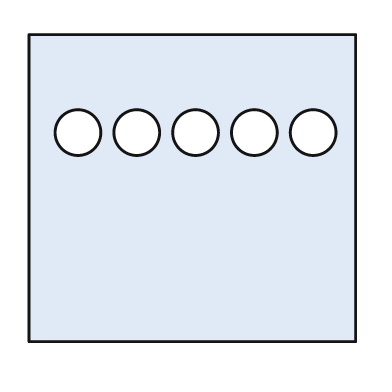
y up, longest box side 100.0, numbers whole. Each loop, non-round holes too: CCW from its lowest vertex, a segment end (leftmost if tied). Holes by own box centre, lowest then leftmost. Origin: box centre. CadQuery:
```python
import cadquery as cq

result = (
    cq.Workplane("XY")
    .moveTo(-50.0, -47.0)
    .lineTo(50.0, -47.0)
    .lineTo(50.0, 47.0)
    .lineTo(-50.0, 47.0)
    .close()
    .moveTo(-35.0, 17.0)
    .circle(7.0)
    .moveTo(-17.0, 17.0)
    .circle(7.0)
    .moveTo(1.0, 17.0)
    .circle(7.0)
    .moveTo(19.0, 17.0)
    .circle(7.0)
    .moveTo(37.0, 17.0)
    .circle(7.0)
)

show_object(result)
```